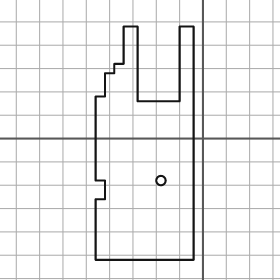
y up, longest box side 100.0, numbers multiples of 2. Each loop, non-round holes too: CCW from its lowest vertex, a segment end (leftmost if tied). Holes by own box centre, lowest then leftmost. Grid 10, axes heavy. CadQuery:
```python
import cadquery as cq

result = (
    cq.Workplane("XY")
    .moveTo(-46.0, -52.0)
    .lineTo(-4.0, -52.0)
    .lineTo(-4.0, 48.0)
    .lineTo(-10.0, 48.0)
    .lineTo(-10.0, 16.0)
    .lineTo(-28.0, 16.0)
    .lineTo(-28.0, 48.0)
    .lineTo(-34.0, 48.0)
    .lineTo(-34.0, 32.0)
    .lineTo(-38.0, 32.0)
    .lineTo(-38.0, 28.0)
    .lineTo(-42.0, 28.0)
    .lineTo(-42.0, 18.0)
    .lineTo(-46.0, 18.0)
    .lineTo(-46.0, -18.0)
    .lineTo(-42.0, -18.0)
    .lineTo(-42.0, -26.0)
    .lineTo(-46.0, -26.0)
    .close()
    .moveTo(-18.0, -18.0)
    .circle(2.0)
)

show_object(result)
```